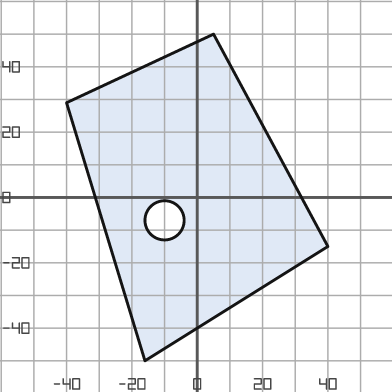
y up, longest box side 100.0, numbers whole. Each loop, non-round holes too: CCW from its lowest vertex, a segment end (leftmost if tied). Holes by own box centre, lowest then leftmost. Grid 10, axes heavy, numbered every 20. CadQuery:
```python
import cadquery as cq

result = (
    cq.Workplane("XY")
    .moveTo(-16.0, -50.0)
    .lineTo(40.0, -15.0)
    .lineTo(5.0, 50.0)
    .lineTo(-40.0, 29.0)
    .close()
    .moveTo(-10.0, -7.0)
    .circle(6.0)
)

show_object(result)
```